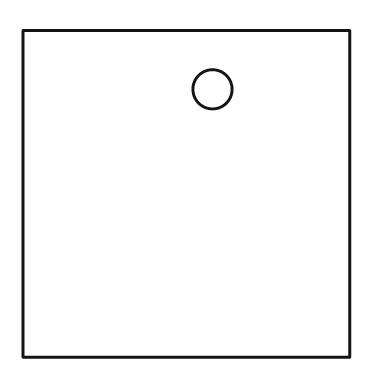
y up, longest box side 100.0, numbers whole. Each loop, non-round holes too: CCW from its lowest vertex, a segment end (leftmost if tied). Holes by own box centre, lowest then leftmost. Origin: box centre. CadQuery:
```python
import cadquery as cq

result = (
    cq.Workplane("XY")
    .moveTo(-50.0, -50.0)
    .lineTo(50.0, -50.0)
    .lineTo(50.0, 50.0)
    .lineTo(-50.0, 50.0)
    .close()
    .moveTo(8.0, 32.0)
    .circle(6.0)
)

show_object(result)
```